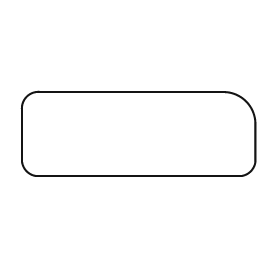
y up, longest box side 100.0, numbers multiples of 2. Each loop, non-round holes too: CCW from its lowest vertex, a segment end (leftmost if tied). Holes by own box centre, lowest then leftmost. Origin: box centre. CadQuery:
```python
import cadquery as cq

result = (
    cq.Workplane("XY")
    .moveTo(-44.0, -18.0)
    .lineTo(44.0, -18.0)
    .threePointArc((48.0, -16.0), (50.0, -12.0))
    .lineTo(50.0, 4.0)
    .threePointArc((46.0, 14.0), (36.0, 18.0))
    .lineTo(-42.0, 18.0)
    .threePointArc((-48.0, 16.0), (-50.0, 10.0))
    .lineTo(-50.0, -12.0)
    .threePointArc((-48.0, -16.0), (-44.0, -18.0))
    .close()
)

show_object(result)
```